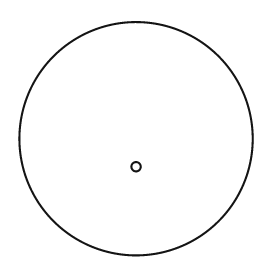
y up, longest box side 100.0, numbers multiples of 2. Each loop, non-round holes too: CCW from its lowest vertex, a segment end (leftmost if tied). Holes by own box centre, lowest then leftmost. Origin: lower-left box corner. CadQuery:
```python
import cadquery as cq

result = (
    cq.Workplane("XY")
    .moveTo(50.0, 50.0)
    .circle(50.0)
    .moveTo(50.0, 38.0)
    .circle(2.0)
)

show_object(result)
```